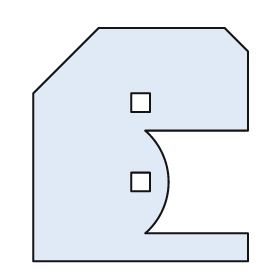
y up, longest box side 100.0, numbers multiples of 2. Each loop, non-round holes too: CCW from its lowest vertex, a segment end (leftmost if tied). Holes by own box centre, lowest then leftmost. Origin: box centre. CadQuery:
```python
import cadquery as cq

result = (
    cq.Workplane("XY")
    .moveTo(-46.0, -50.0)
    .lineTo(46.0, -50.0)
    .lineTo(46.0, -38.0)
    .lineTo(2.0, -38.0)
    .threePointArc((12.0, -16.0), (2.0, 6.0))
    .lineTo(46.0, 6.0)
    .lineTo(46.0, 40.0)
    .lineTo(36.0, 50.0)
    .lineTo(-18.0, 50.0)
    .lineTo(-46.0, 22.0)
    .close()
    .moveTo(-4.0, -20.0)
    .lineTo(4.0, -20.0)
    .lineTo(4.0, -12.0)
    .lineTo(-4.0, -12.0)
    .close()
    .moveTo(-4.0, 14.0)
    .lineTo(4.0, 14.0)
    .lineTo(4.0, 22.0)
    .lineTo(-4.0, 22.0)
    .close()
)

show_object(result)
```